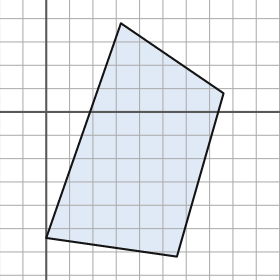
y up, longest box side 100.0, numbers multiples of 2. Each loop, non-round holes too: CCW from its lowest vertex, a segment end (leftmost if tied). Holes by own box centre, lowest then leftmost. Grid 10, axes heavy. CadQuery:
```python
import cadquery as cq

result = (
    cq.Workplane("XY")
    .moveTo(56.0, -62.0)
    .lineTo(76.0, 8.0)
    .lineTo(32.0, 38.0)
    .lineTo(0.0, -54.0)
    .close()
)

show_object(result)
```